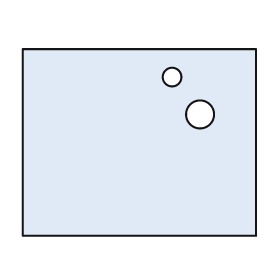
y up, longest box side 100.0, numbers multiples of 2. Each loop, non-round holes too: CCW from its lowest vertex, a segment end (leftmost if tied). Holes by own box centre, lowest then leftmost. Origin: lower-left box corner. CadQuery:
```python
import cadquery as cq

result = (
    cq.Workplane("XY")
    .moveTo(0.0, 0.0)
    .lineTo(100.0, 0.0)
    .lineTo(100.0, 80.0)
    .lineTo(0.0, 80.0)
    .close()
    .moveTo(76.0, 52.0)
    .circle(6.0)
    .moveTo(64.0, 68.0)
    .circle(4.0)
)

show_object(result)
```